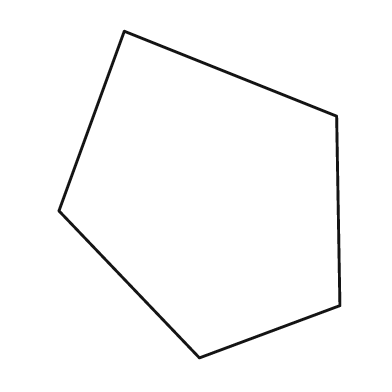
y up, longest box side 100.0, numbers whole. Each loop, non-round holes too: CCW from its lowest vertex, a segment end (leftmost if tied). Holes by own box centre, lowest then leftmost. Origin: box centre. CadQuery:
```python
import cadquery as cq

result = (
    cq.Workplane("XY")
    .moveTo(0.0, -50.0)
    .lineTo(43.0, -34.0)
    .lineTo(42.0, 24.0)
    .lineTo(-23.0, 50.0)
    .lineTo(-43.0, -5.0)
    .close()
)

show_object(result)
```